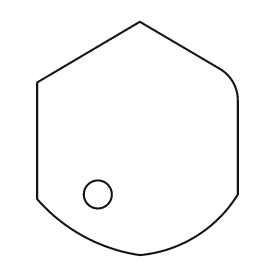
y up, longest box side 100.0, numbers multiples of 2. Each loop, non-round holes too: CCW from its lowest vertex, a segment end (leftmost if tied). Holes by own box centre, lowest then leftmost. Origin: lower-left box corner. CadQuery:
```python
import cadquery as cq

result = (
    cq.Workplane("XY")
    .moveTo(44.0, 0.0)
    .threePointArc((68.0, 8.0), (86.0, 26.0))
    .lineTo(86.0, 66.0)
    .threePointArc((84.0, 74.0), (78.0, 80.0))
    .lineTo(44.0, 100.0)
    .lineTo(0.0, 74.0)
    .lineTo(0.0, 24.0)
    .threePointArc((20.0, 8.0), (44.0, 0.0))
    .close()
    .moveTo(26.0, 26.0)
    .circle(6.0)
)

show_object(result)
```